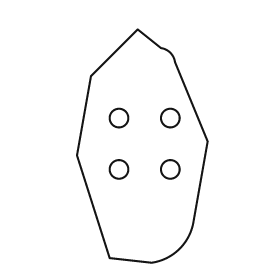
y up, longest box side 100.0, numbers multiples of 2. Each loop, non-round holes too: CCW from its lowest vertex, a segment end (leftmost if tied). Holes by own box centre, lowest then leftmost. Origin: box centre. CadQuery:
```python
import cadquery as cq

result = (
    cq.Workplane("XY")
    .moveTo(4.0, -50.0)
    .threePointArc((16.0, -44.0), (22.0, -32.0))
    .lineTo(28.0, 2.0)
    .lineTo(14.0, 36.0)
    .threePointArc((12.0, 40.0), (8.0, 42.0))
    .lineTo(-2.0, 50.0)
    .lineTo(-22.0, 30.0)
    .lineTo(-28.0, -4.0)
    .lineTo(-14.0, -48.0)
    .close()
    .moveTo(-10.0, -10.0)
    .circle(4.0)
    .moveTo(12.0, -10.0)
    .circle(4.0)
    .moveTo(-10.0, 12.0)
    .circle(4.0)
    .moveTo(12.0, 12.0)
    .circle(4.0)
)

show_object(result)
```